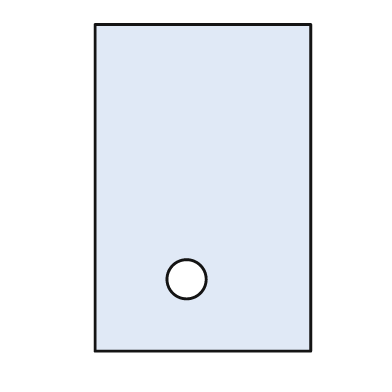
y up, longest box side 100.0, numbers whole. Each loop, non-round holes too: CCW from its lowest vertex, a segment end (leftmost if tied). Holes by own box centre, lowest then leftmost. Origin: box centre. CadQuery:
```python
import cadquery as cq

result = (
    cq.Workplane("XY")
    .moveTo(-33.0, -50.0)
    .lineTo(33.0, -50.0)
    .lineTo(33.0, 50.0)
    .lineTo(-33.0, 50.0)
    .close()
    .moveTo(-5.0, -28.0)
    .circle(6.0)
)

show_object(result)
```